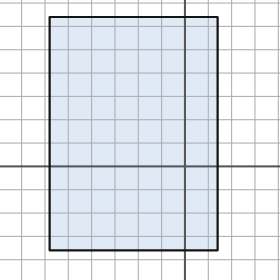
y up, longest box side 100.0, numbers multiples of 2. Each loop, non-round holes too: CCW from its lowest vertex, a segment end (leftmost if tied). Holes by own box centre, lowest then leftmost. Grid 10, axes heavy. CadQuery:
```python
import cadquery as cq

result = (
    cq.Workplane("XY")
    .moveTo(-58.0, -36.0)
    .lineTo(14.0, -36.0)
    .lineTo(14.0, 64.0)
    .lineTo(-58.0, 64.0)
    .close()
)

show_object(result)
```